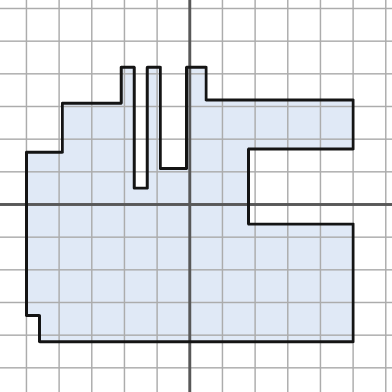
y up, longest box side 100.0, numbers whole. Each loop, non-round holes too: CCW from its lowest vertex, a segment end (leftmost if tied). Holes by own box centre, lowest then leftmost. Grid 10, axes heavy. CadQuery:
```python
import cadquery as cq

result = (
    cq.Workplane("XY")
    .moveTo(-46.0, -42.0)
    .lineTo(50.0, -42.0)
    .lineTo(50.0, -6.0)
    .lineTo(18.0, -6.0)
    .lineTo(18.0, 17.0)
    .lineTo(50.0, 17.0)
    .lineTo(50.0, 32.0)
    .lineTo(5.0, 32.0)
    .lineTo(5.0, 42.0)
    .lineTo(-1.0, 42.0)
    .lineTo(-1.0, 11.0)
    .lineTo(-9.0, 11.0)
    .lineTo(-9.0, 42.0)
    .lineTo(-13.0, 42.0)
    .lineTo(-13.0, 5.0)
    .lineTo(-17.0, 5.0)
    .lineTo(-17.0, 42.0)
    .lineTo(-21.0, 42.0)
    .lineTo(-21.0, 31.0)
    .lineTo(-39.0, 31.0)
    .lineTo(-39.0, 16.0)
    .lineTo(-50.0, 16.0)
    .lineTo(-50.0, -34.0)
    .lineTo(-46.0, -34.0)
    .close()
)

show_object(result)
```